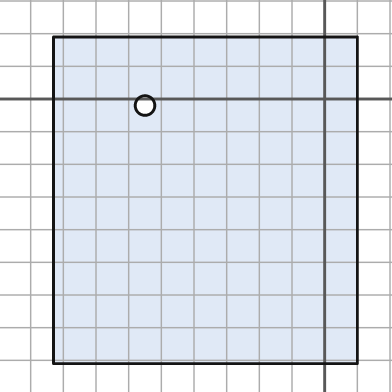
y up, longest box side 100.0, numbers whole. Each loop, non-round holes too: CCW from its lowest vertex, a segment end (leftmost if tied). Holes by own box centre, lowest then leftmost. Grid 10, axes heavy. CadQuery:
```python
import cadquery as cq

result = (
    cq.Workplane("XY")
    .moveTo(-83.0, -81.0)
    .lineTo(10.0, -81.0)
    .lineTo(10.0, 19.0)
    .lineTo(-83.0, 19.0)
    .close()
    .moveTo(-55.0, -2.0)
    .circle(3.0)
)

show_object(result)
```